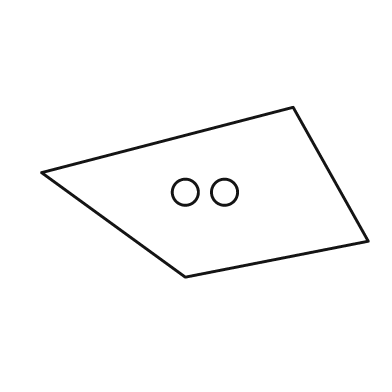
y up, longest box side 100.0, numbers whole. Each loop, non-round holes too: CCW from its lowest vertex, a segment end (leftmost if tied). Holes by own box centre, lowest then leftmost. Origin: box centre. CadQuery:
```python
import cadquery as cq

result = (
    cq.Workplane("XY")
    .moveTo(-6.0, -26.0)
    .lineTo(50.0, -15.0)
    .lineTo(27.0, 26.0)
    .lineTo(-50.0, 6.0)
    .close()
    .moveTo(-6.0, 0.0)
    .circle(4.0)
    .moveTo(6.0, 0.0)
    .circle(4.0)
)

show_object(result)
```